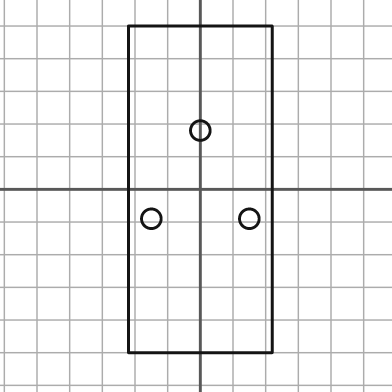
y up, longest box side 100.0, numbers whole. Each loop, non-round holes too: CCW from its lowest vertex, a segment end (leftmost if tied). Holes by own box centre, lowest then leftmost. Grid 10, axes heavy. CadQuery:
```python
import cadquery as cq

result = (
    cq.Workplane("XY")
    .moveTo(-22.0, -50.0)
    .lineTo(22.0, -50.0)
    .lineTo(22.0, 50.0)
    .lineTo(-22.0, 50.0)
    .close()
    .moveTo(-15.0, -9.0)
    .circle(3.0)
    .moveTo(15.0, -9.0)
    .circle(3.0)
    .moveTo(0.0, 18.0)
    .circle(3.0)
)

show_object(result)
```